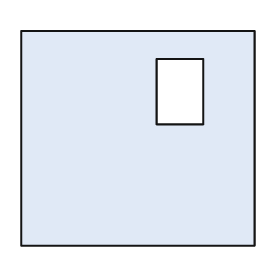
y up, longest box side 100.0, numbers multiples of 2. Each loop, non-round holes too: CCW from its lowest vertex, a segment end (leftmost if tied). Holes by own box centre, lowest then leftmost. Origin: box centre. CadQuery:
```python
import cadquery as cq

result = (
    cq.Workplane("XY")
    .moveTo(-50.0, -46.0)
    .lineTo(50.0, -46.0)
    .lineTo(50.0, 46.0)
    .lineTo(-50.0, 46.0)
    .close()
    .moveTo(8.0, 6.0)
    .lineTo(28.0, 6.0)
    .lineTo(28.0, 34.0)
    .lineTo(8.0, 34.0)
    .close()
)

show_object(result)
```